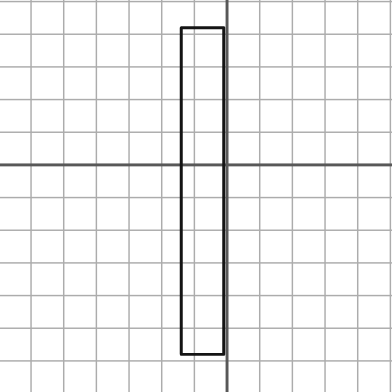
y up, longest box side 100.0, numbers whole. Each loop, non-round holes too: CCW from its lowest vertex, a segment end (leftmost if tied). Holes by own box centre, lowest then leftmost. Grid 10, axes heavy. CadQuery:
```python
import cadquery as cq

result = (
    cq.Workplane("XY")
    .moveTo(-14.0, -58.0)
    .lineTo(-1.0, -58.0)
    .lineTo(-1.0, 42.0)
    .lineTo(-14.0, 42.0)
    .close()
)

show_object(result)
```